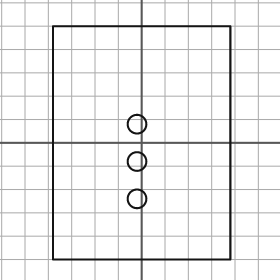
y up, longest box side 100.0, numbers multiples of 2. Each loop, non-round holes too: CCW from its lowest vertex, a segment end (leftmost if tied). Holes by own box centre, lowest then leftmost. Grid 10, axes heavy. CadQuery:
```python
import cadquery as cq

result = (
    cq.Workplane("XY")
    .moveTo(-38.0, -50.0)
    .lineTo(38.0, -50.0)
    .lineTo(38.0, 50.0)
    .lineTo(-38.0, 50.0)
    .close()
    .moveTo(-2.0, -24.0)
    .circle(4.0)
    .moveTo(-2.0, -8.0)
    .circle(4.0)
    .moveTo(-2.0, 8.0)
    .circle(4.0)
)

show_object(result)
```